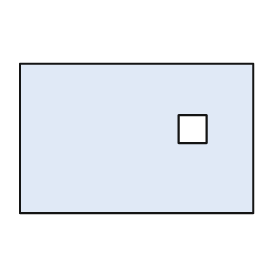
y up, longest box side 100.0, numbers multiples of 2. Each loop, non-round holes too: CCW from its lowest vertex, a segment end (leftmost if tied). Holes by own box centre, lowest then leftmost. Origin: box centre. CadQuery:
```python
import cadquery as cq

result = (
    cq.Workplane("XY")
    .moveTo(-50.0, -32.0)
    .lineTo(50.0, -32.0)
    .lineTo(50.0, 32.0)
    .lineTo(-50.0, 32.0)
    .close()
    .moveTo(18.0, -2.0)
    .lineTo(30.0, -2.0)
    .lineTo(30.0, 10.0)
    .lineTo(18.0, 10.0)
    .close()
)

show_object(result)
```